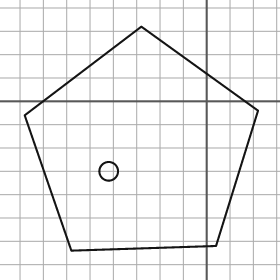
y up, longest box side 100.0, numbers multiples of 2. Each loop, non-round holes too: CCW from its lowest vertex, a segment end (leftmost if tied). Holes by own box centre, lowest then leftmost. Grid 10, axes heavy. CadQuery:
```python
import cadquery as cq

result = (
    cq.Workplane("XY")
    .moveTo(-58.0, -64.0)
    .lineTo(4.0, -62.0)
    .lineTo(22.0, -4.0)
    .lineTo(-28.0, 32.0)
    .lineTo(-78.0, -6.0)
    .close()
    .moveTo(-42.0, -30.0)
    .circle(4.0)
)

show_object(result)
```